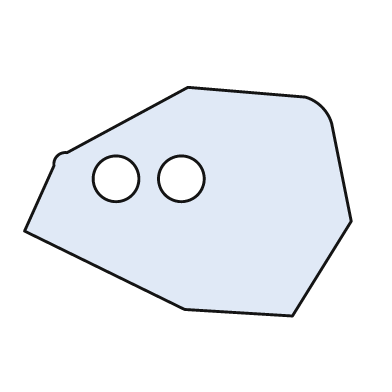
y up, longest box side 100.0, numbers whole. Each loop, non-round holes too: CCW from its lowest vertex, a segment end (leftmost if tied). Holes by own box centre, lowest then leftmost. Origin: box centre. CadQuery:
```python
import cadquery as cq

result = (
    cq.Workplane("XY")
    .moveTo(32.0, -35.0)
    .lineTo(50.0, -6.0)
    .lineTo(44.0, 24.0)
    .threePointArc((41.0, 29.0), (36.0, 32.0))
    .lineTo(0.0, 35.0)
    .lineTo(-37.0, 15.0)
    .threePointArc((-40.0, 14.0), (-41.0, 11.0))
    .lineTo(-50.0, -9.0)
    .lineTo(-1.0, -33.0)
    .close()
    .moveTo(-22.0, 7.0)
    .circle(7.0)
    .moveTo(-2.0, 7.0)
    .circle(7.0)
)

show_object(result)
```